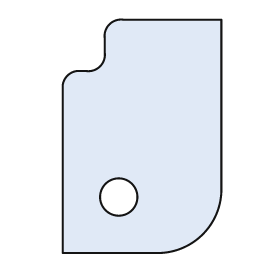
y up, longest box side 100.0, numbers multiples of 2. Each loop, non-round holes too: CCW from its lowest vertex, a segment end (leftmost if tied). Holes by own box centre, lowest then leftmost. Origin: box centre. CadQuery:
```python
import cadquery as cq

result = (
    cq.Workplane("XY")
    .moveTo(-34.0, -50.0)
    .lineTo(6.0, -50.0)
    .threePointArc((26.0, -42.0), (34.0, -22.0))
    .lineTo(34.0, 50.0)
    .lineTo(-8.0, 50.0)
    .threePointArc((-14.0, 48.0), (-16.0, 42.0))
    .lineTo(-16.0, 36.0)
    .threePointArc((-18.0, 30.0), (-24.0, 28.0))
    .lineTo(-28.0, 28.0)
    .threePointArc((-32.0, 26.0), (-34.0, 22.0))
    .close()
    .moveTo(-10.0, -26.0)
    .circle(8.0)
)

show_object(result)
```